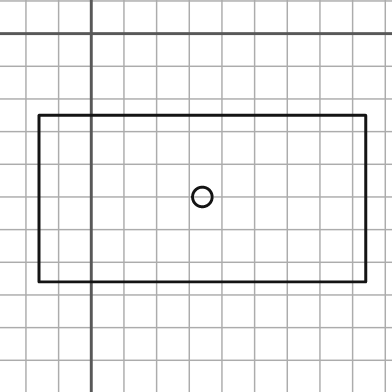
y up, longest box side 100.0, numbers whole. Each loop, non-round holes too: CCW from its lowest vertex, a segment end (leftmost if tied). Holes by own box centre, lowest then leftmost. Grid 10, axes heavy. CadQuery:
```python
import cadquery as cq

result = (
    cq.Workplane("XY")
    .moveTo(-16.0, -76.0)
    .lineTo(84.0, -76.0)
    .lineTo(84.0, -25.0)
    .lineTo(-16.0, -25.0)
    .close()
    .moveTo(34.0, -50.0)
    .circle(3.0)
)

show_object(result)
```